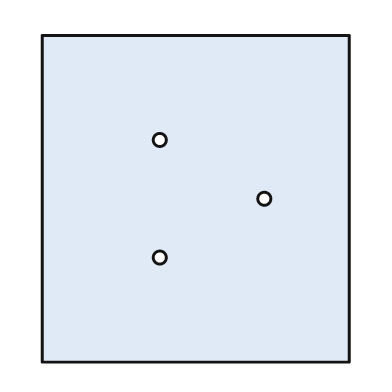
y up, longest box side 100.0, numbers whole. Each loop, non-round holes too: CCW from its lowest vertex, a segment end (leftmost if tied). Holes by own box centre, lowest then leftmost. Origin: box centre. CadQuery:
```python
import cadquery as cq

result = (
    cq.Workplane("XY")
    .moveTo(-47.0, -50.0)
    .lineTo(47.0, -50.0)
    .lineTo(47.0, 50.0)
    .lineTo(-47.0, 50.0)
    .close()
    .moveTo(-11.0, -18.0)
    .circle(2.0)
    .moveTo(21.0, 0.0)
    .circle(2.0)
    .moveTo(-11.0, 18.0)
    .circle(2.0)
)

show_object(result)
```